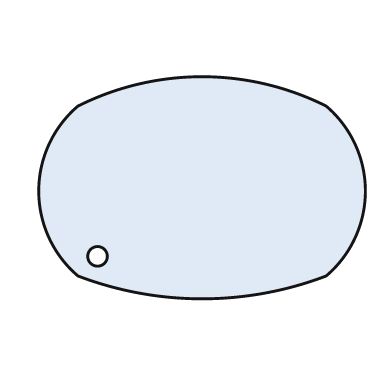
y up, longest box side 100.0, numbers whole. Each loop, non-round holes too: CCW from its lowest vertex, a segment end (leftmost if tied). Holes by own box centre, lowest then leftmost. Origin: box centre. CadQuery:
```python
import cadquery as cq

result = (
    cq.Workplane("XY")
    .moveTo(-38.0, -27.0)
    .threePointArc((0.0, -34.0), (38.0, -27.0))
    .threePointArc((50.0, -1.0), (38.0, 25.0))
    .threePointArc((0.0, 34.0), (-38.0, 25.0))
    .threePointArc((-50.0, -1.0), (-38.0, -27.0))
    .close()
    .moveTo(-32.0, -21.0)
    .circle(3.0)
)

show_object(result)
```